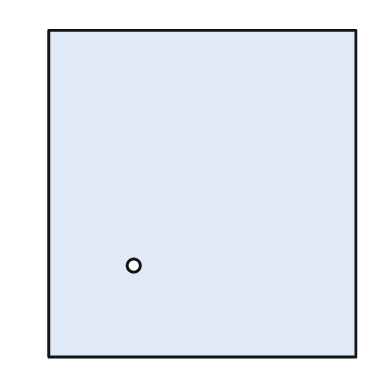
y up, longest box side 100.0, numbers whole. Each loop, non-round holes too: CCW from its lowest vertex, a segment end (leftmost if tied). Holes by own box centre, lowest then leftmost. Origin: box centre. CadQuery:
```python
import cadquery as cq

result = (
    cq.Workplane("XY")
    .moveTo(-47.0, -50.0)
    .lineTo(47.0, -50.0)
    .lineTo(47.0, 50.0)
    .lineTo(-47.0, 50.0)
    .close()
    .moveTo(-21.0, -22.0)
    .circle(2.0)
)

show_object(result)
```